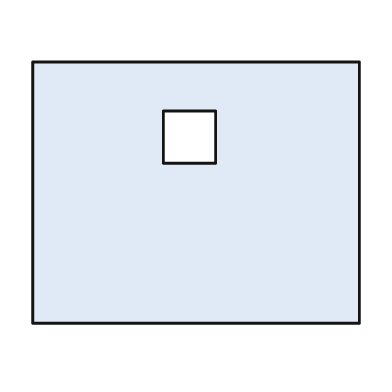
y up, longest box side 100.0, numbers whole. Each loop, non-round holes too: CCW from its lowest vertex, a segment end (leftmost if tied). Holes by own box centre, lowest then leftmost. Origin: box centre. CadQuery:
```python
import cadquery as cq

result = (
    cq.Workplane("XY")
    .moveTo(-50.0, -40.0)
    .lineTo(50.0, -40.0)
    .lineTo(50.0, 40.0)
    .lineTo(-50.0, 40.0)
    .close()
    .moveTo(-10.0, 9.0)
    .lineTo(6.0, 9.0)
    .lineTo(6.0, 25.0)
    .lineTo(-10.0, 25.0)
    .close()
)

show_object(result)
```